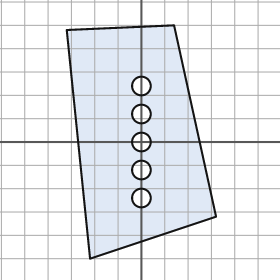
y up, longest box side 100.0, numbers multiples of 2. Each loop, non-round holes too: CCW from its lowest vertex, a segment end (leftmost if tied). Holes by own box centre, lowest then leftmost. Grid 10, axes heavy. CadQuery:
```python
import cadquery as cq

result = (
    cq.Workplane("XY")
    .moveTo(-22.0, -50.0)
    .lineTo(32.0, -32.0)
    .lineTo(14.0, 50.0)
    .lineTo(-32.0, 48.0)
    .close()
    .moveTo(0.0, -24.0)
    .circle(4.0)
    .moveTo(0.0, -12.0)
    .circle(4.0)
    .moveTo(0.0, 0.0)
    .circle(4.0)
    .moveTo(0.0, 12.0)
    .circle(4.0)
    .moveTo(0.0, 24.0)
    .circle(4.0)
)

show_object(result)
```